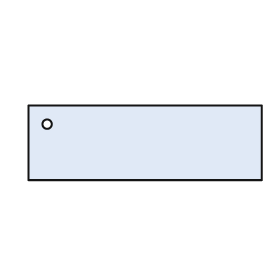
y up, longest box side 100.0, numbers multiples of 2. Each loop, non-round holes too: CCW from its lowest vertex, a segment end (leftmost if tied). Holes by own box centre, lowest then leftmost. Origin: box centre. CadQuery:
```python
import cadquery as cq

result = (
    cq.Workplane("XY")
    .moveTo(-50.0, -16.0)
    .lineTo(50.0, -16.0)
    .lineTo(50.0, 16.0)
    .lineTo(-50.0, 16.0)
    .close()
    .moveTo(-42.0, 8.0)
    .circle(2.0)
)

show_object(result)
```